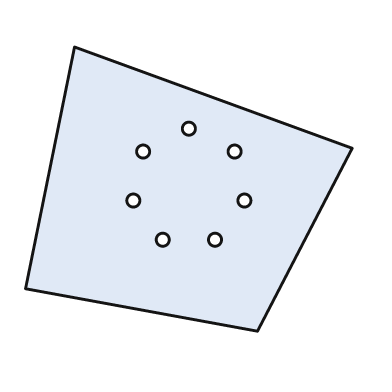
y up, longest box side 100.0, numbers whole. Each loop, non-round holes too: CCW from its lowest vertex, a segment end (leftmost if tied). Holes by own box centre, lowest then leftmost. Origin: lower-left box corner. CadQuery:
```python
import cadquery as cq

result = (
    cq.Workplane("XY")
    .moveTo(71.0, 0.0)
    .lineTo(100.0, 56.0)
    .lineTo(15.0, 87.0)
    .lineTo(0.0, 13.0)
    .close()
    .moveTo(42.0, 28.0)
    .circle(2.0)
    .moveTo(58.0, 28.0)
    .circle(2.0)
    .moveTo(33.0, 40.0)
    .circle(2.0)
    .moveTo(67.0, 40.0)
    .circle(2.0)
    .moveTo(36.0, 55.0)
    .circle(2.0)
    .moveTo(64.0, 55.0)
    .circle(2.0)
    .moveTo(50.0, 62.0)
    .circle(2.0)
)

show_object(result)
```